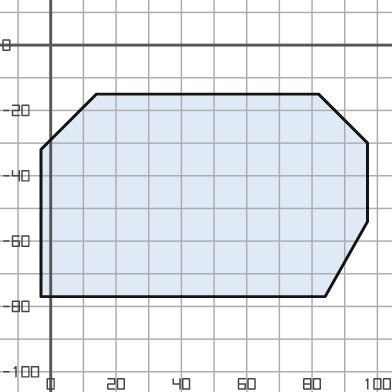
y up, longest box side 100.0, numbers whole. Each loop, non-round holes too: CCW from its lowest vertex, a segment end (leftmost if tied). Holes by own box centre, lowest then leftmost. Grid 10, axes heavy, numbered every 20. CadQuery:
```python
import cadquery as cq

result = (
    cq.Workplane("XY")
    .moveTo(-3.0, -77.0)
    .lineTo(84.0, -77.0)
    .lineTo(97.0, -54.0)
    .lineTo(97.0, -30.0)
    .lineTo(82.0, -15.0)
    .lineTo(14.0, -15.0)
    .lineTo(-3.0, -32.0)
    .close()
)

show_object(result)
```